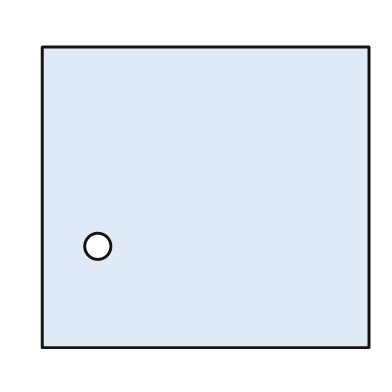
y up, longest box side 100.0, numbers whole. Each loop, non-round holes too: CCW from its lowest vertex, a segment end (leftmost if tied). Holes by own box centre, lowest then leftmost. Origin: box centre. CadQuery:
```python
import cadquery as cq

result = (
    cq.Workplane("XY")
    .moveTo(-50.0, -46.0)
    .lineTo(50.0, -46.0)
    .lineTo(50.0, 46.0)
    .lineTo(-50.0, 46.0)
    .close()
    .moveTo(-33.0, -15.0)
    .circle(4.0)
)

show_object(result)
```